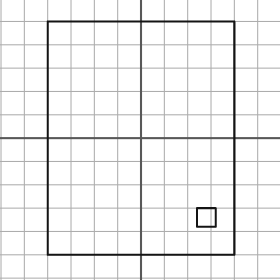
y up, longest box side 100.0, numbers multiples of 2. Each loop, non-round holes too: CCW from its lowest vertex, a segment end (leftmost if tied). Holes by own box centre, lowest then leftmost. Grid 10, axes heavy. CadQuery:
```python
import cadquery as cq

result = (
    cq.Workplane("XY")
    .moveTo(-40.0, -50.0)
    .lineTo(40.0, -50.0)
    .lineTo(40.0, 50.0)
    .lineTo(-40.0, 50.0)
    .close()
    .moveTo(24.0, -38.0)
    .lineTo(32.0, -38.0)
    .lineTo(32.0, -30.0)
    .lineTo(24.0, -30.0)
    .close()
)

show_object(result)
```